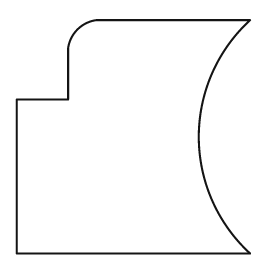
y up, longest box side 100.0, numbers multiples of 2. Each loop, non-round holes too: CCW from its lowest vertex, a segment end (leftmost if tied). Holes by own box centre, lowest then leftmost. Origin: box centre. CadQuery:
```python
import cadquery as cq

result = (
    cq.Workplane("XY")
    .moveTo(-50.0, -50.0)
    .lineTo(50.0, -50.0)
    .threePointArc((28.0, 0.0), (50.0, 50.0))
    .lineTo(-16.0, 50.0)
    .threePointArc((-24.0, 46.0), (-28.0, 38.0))
    .lineTo(-28.0, 16.0)
    .lineTo(-50.0, 16.0)
    .close()
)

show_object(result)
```